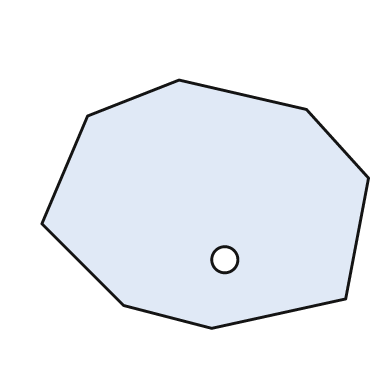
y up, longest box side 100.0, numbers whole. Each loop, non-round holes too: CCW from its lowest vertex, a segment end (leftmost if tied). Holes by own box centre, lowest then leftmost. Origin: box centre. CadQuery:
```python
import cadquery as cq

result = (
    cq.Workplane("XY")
    .moveTo(2.0, -38.0)
    .lineTo(43.0, -29.0)
    .lineTo(50.0, 8.0)
    .lineTo(31.0, 29.0)
    .lineTo(-8.0, 38.0)
    .lineTo(-36.0, 27.0)
    .lineTo(-50.0, -6.0)
    .lineTo(-25.0, -31.0)
    .close()
    .moveTo(6.0, -17.0)
    .circle(4.0)
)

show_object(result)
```